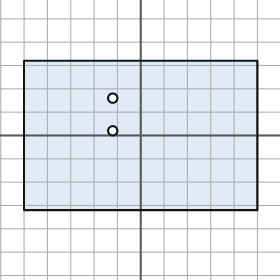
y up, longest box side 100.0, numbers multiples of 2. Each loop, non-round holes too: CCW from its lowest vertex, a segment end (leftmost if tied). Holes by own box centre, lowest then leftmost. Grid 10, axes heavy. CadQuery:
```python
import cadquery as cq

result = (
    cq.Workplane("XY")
    .moveTo(-50.0, -32.0)
    .lineTo(50.0, -32.0)
    .lineTo(50.0, 32.0)
    .lineTo(-50.0, 32.0)
    .close()
    .moveTo(-12.0, 2.0)
    .circle(2.0)
    .moveTo(-12.0, 16.0)
    .circle(2.0)
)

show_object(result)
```